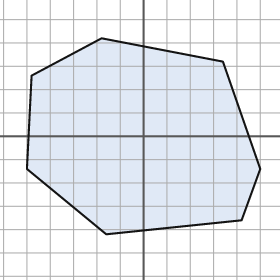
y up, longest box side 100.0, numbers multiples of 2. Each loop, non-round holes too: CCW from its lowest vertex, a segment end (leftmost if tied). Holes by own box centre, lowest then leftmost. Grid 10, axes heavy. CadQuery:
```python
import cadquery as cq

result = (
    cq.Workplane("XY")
    .moveTo(-16.0, -42.0)
    .lineTo(42.0, -36.0)
    .lineTo(50.0, -14.0)
    .lineTo(34.0, 32.0)
    .lineTo(-18.0, 42.0)
    .lineTo(-48.0, 26.0)
    .lineTo(-50.0, -14.0)
    .close()
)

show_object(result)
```